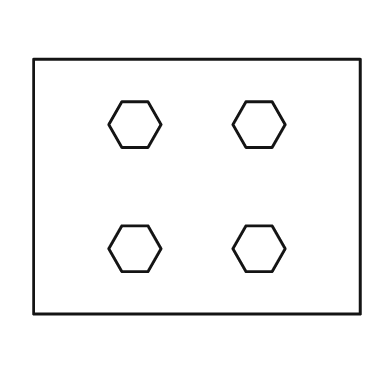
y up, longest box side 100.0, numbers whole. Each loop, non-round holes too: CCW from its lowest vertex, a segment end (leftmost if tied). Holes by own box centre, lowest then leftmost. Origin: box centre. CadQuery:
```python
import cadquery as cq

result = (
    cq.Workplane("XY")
    .moveTo(-50.0, -39.0)
    .lineTo(50.0, -39.0)
    .lineTo(50.0, 39.0)
    .lineTo(-50.0, 39.0)
    .close()
    .moveTo(-23.0, -26.0)
    .lineTo(-15.0, -26.0)
    .lineTo(-11.0, -19.0)
    .lineTo(-15.0, -12.0)
    .lineTo(-23.0, -12.0)
    .lineTo(-27.0, -19.0)
    .close()
    .moveTo(15.0, -26.0)
    .lineTo(23.0, -26.0)
    .lineTo(27.0, -19.0)
    .lineTo(23.0, -12.0)
    .lineTo(15.0, -12.0)
    .lineTo(11.0, -19.0)
    .close()
    .moveTo(-23.0, 12.0)
    .lineTo(-15.0, 12.0)
    .lineTo(-11.0, 19.0)
    .lineTo(-15.0, 26.0)
    .lineTo(-23.0, 26.0)
    .lineTo(-27.0, 19.0)
    .close()
    .moveTo(15.0, 12.0)
    .lineTo(23.0, 12.0)
    .lineTo(27.0, 19.0)
    .lineTo(23.0, 26.0)
    .lineTo(15.0, 26.0)
    .lineTo(11.0, 19.0)
    .close()
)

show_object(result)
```